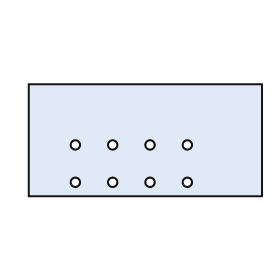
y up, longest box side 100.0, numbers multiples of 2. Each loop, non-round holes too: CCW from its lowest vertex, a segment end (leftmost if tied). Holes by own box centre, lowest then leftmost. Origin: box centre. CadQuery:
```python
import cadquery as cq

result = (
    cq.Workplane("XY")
    .moveTo(-50.0, -24.0)
    .lineTo(50.0, -24.0)
    .lineTo(50.0, 24.0)
    .lineTo(-50.0, 24.0)
    .close()
    .moveTo(-30.0, -18.0)
    .circle(2.0)
    .moveTo(-14.0, -18.0)
    .circle(2.0)
    .moveTo(2.0, -18.0)
    .circle(2.0)
    .moveTo(18.0, -18.0)
    .circle(2.0)
    .moveTo(-30.0, -2.0)
    .circle(2.0)
    .moveTo(-14.0, -2.0)
    .circle(2.0)
    .moveTo(2.0, -2.0)
    .circle(2.0)
    .moveTo(18.0, -2.0)
    .circle(2.0)
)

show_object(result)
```